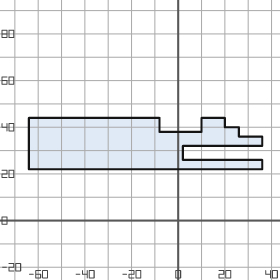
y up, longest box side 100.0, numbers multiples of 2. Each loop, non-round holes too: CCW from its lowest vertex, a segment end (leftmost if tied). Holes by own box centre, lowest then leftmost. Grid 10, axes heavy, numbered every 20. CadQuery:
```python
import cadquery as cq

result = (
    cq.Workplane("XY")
    .moveTo(-64.0, 22.0)
    .lineTo(36.0, 22.0)
    .lineTo(36.0, 26.0)
    .lineTo(2.0, 26.0)
    .lineTo(2.0, 32.0)
    .lineTo(36.0, 32.0)
    .lineTo(36.0, 36.0)
    .lineTo(26.0, 36.0)
    .lineTo(26.0, 40.0)
    .lineTo(20.0, 40.0)
    .lineTo(20.0, 44.0)
    .lineTo(10.0, 44.0)
    .lineTo(10.0, 38.0)
    .lineTo(-8.0, 38.0)
    .lineTo(-8.0, 44.0)
    .lineTo(-64.0, 44.0)
    .close()
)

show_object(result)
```